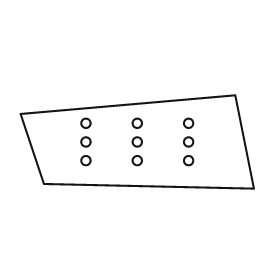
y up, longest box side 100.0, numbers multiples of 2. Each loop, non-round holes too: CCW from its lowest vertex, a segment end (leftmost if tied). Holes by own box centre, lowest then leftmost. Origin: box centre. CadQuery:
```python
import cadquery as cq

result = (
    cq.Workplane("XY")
    .moveTo(50.0, -20.0)
    .lineTo(42.0, 20.0)
    .lineTo(-50.0, 12.0)
    .lineTo(-40.0, -18.0)
    .close()
    .moveTo(-22.0, -8.0)
    .circle(2.0)
    .moveTo(0.0, -8.0)
    .circle(2.0)
    .moveTo(22.0, -8.0)
    .circle(2.0)
    .moveTo(-22.0, 0.0)
    .circle(2.0)
    .moveTo(0.0, 0.0)
    .circle(2.0)
    .moveTo(22.0, 0.0)
    .circle(2.0)
    .moveTo(-22.0, 8.0)
    .circle(2.0)
    .moveTo(0.0, 8.0)
    .circle(2.0)
    .moveTo(22.0, 8.0)
    .circle(2.0)
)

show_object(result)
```